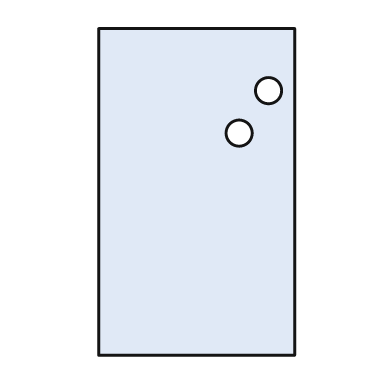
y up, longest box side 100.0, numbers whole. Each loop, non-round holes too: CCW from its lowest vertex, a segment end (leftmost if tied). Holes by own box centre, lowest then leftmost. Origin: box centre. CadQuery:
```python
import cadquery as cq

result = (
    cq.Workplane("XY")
    .moveTo(-30.0, -50.0)
    .lineTo(30.0, -50.0)
    .lineTo(30.0, 50.0)
    .lineTo(-30.0, 50.0)
    .close()
    .moveTo(13.0, 18.0)
    .circle(4.0)
    .moveTo(22.0, 31.0)
    .circle(4.0)
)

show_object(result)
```